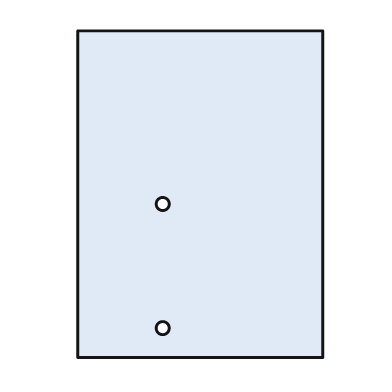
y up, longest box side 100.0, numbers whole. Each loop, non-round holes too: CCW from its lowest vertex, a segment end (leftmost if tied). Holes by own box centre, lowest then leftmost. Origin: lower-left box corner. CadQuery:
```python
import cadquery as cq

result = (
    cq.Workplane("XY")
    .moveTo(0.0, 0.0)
    .lineTo(75.0, 0.0)
    .lineTo(75.0, 100.0)
    .lineTo(0.0, 100.0)
    .close()
    .moveTo(26.0, 9.0)
    .circle(2.0)
    .moveTo(26.0, 47.0)
    .circle(2.0)
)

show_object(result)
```